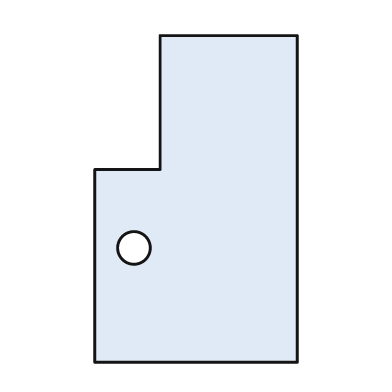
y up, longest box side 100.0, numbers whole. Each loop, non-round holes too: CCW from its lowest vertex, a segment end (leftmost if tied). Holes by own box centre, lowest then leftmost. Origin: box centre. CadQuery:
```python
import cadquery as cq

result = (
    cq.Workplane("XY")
    .moveTo(-31.0, -50.0)
    .lineTo(31.0, -50.0)
    .lineTo(31.0, 50.0)
    .lineTo(-11.0, 50.0)
    .lineTo(-11.0, 9.0)
    .lineTo(-31.0, 9.0)
    .close()
    .moveTo(-19.0, -15.0)
    .circle(5.0)
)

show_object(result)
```